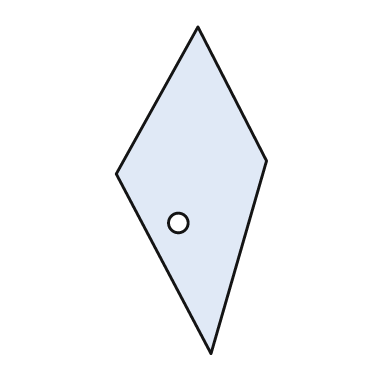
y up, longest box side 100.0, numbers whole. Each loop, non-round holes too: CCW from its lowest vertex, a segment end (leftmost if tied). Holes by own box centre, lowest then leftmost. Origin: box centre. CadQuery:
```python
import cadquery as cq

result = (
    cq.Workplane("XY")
    .moveTo(6.0, -50.0)
    .lineTo(23.0, 9.0)
    .lineTo(2.0, 50.0)
    .lineTo(-23.0, 5.0)
    .close()
    .moveTo(-4.0, -10.0)
    .circle(3.0)
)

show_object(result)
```